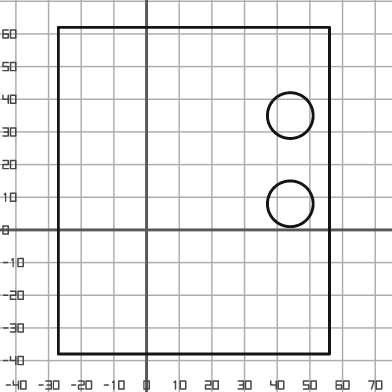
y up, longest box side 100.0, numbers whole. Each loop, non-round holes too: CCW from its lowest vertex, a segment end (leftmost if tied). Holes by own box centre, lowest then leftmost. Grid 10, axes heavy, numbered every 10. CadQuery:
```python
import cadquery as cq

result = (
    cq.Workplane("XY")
    .moveTo(-27.0, -38.0)
    .lineTo(56.0, -38.0)
    .lineTo(56.0, 62.0)
    .lineTo(-27.0, 62.0)
    .close()
    .moveTo(44.0, 8.0)
    .circle(7.0)
    .moveTo(44.0, 35.0)
    .circle(7.0)
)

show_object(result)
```